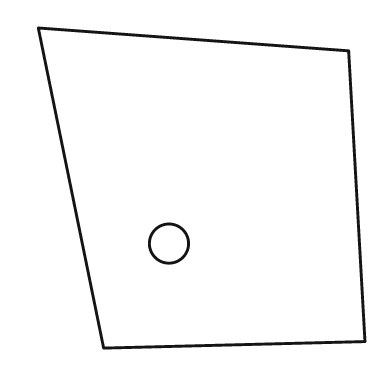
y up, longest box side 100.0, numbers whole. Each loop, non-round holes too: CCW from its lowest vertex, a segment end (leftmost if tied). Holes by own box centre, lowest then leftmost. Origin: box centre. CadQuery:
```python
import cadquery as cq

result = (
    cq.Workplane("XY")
    .moveTo(-30.0, -49.0)
    .lineTo(50.0, -47.0)
    .lineTo(45.0, 42.0)
    .lineTo(-50.0, 49.0)
    .close()
    .moveTo(-10.0, -17.0)
    .circle(6.0)
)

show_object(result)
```